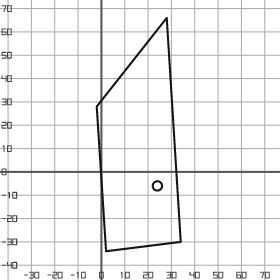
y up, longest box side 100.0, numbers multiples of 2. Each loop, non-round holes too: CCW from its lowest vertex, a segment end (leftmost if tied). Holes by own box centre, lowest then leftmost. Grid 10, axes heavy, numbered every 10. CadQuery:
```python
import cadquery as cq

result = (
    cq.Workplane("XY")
    .moveTo(2.0, -34.0)
    .lineTo(34.0, -30.0)
    .lineTo(28.0, 66.0)
    .lineTo(-2.0, 28.0)
    .close()
    .moveTo(24.0, -6.0)
    .circle(2.0)
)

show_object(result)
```